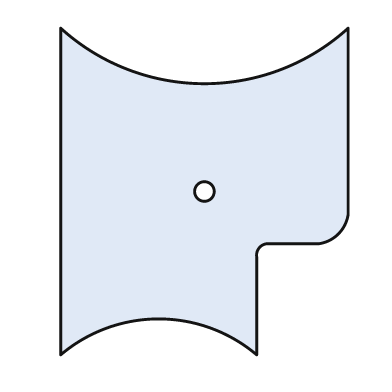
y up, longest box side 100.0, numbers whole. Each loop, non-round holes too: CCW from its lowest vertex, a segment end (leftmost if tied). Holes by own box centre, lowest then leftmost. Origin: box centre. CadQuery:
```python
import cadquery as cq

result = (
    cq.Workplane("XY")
    .moveTo(-44.0, -50.0)
    .threePointArc((-14.0, -39.0), (16.0, -50.0))
    .lineTo(16.0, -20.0)
    .threePointArc((17.0, -17.0), (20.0, -16.0))
    .lineTo(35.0, -16.0)
    .threePointArc((41.0, -13.0), (44.0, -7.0))
    .lineTo(44.0, 50.0)
    .threePointArc((0.0, 33.0), (-44.0, 50.0))
    .close()
    .moveTo(0.0, 0.0)
    .circle(3.0)
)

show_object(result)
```